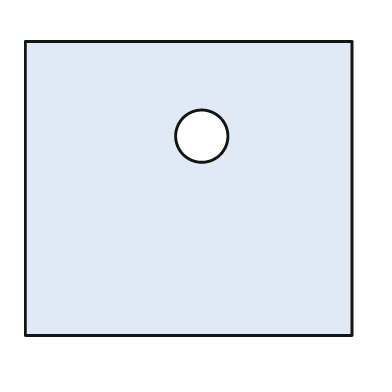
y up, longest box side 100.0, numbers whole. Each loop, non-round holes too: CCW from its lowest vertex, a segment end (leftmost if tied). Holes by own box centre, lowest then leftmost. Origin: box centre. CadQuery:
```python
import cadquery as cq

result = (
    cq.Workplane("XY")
    .moveTo(-50.0, -45.0)
    .lineTo(50.0, -45.0)
    .lineTo(50.0, 45.0)
    .lineTo(-50.0, 45.0)
    .close()
    .moveTo(4.0, 16.0)
    .circle(8.0)
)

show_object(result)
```